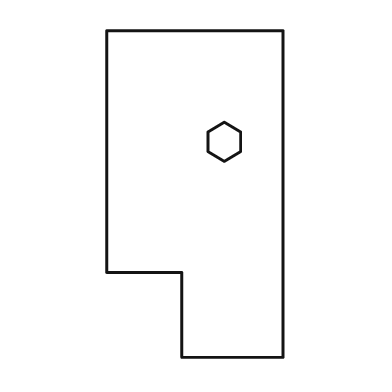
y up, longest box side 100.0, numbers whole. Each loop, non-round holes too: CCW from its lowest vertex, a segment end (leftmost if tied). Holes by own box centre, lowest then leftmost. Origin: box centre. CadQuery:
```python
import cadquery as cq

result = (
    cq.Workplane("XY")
    .moveTo(-4.0, -50.0)
    .lineTo(27.0, -50.0)
    .lineTo(27.0, 50.0)
    .lineTo(-27.0, 50.0)
    .lineTo(-27.0, -24.0)
    .lineTo(-4.0, -24.0)
    .close()
    .moveTo(9.0, 10.0)
    .lineTo(14.0, 13.0)
    .lineTo(14.0, 19.0)
    .lineTo(9.0, 22.0)
    .lineTo(4.0, 19.0)
    .lineTo(4.0, 13.0)
    .close()
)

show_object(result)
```